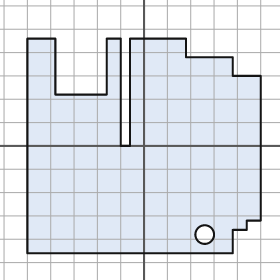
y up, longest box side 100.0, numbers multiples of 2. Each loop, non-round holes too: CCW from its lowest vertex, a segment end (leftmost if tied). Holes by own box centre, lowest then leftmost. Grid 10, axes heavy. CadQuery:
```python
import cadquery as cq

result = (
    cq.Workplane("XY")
    .moveTo(-50.0, -46.0)
    .lineTo(38.0, -46.0)
    .lineTo(38.0, -36.0)
    .lineTo(44.0, -36.0)
    .lineTo(44.0, -32.0)
    .lineTo(50.0, -32.0)
    .lineTo(50.0, 30.0)
    .lineTo(38.0, 30.0)
    .lineTo(38.0, 38.0)
    .lineTo(18.0, 38.0)
    .lineTo(18.0, 46.0)
    .lineTo(-6.0, 46.0)
    .lineTo(-6.0, 0.0)
    .lineTo(-10.0, 0.0)
    .lineTo(-10.0, 46.0)
    .lineTo(-16.0, 46.0)
    .lineTo(-16.0, 22.0)
    .lineTo(-38.0, 22.0)
    .lineTo(-38.0, 46.0)
    .lineTo(-50.0, 46.0)
    .close()
    .moveTo(26.0, -38.0)
    .circle(4.0)
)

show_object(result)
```